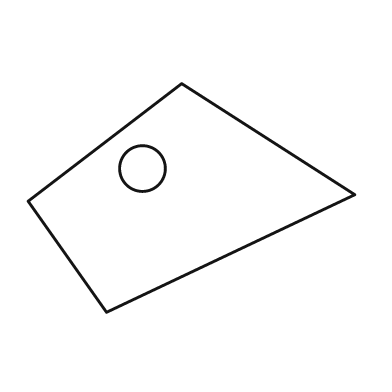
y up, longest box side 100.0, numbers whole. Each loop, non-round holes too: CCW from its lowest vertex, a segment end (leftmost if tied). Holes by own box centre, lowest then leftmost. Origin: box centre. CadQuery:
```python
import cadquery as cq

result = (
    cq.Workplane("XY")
    .moveTo(-26.0, -35.0)
    .lineTo(50.0, 1.0)
    .lineTo(-3.0, 35.0)
    .lineTo(-50.0, -1.0)
    .close()
    .moveTo(-15.0, 9.0)
    .circle(7.0)
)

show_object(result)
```